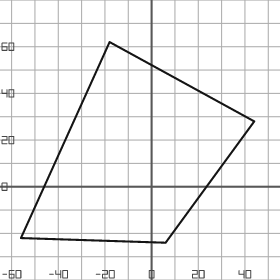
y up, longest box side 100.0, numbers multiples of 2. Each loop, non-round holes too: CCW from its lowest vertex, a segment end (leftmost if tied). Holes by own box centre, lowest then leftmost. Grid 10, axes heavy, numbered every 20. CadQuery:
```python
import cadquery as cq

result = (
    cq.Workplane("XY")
    .moveTo(6.0, -24.0)
    .lineTo(44.0, 28.0)
    .lineTo(-18.0, 62.0)
    .lineTo(-56.0, -22.0)
    .close()
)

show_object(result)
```